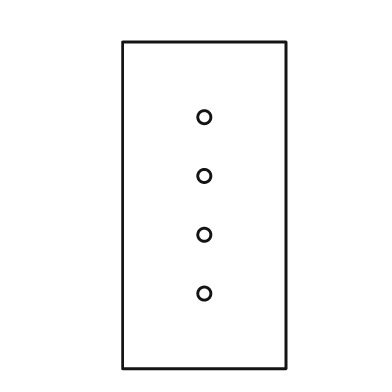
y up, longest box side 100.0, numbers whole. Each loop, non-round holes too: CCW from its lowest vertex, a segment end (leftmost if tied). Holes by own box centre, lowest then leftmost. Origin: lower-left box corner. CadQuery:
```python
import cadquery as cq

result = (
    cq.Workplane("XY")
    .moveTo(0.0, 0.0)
    .lineTo(50.0, 0.0)
    .lineTo(50.0, 100.0)
    .lineTo(0.0, 100.0)
    .close()
    .moveTo(25.0, 23.0)
    .circle(2.0)
    .moveTo(25.0, 41.0)
    .circle(2.0)
    .moveTo(25.0, 59.0)
    .circle(2.0)
    .moveTo(25.0, 77.0)
    .circle(2.0)
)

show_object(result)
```